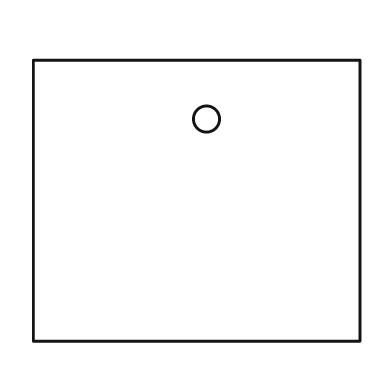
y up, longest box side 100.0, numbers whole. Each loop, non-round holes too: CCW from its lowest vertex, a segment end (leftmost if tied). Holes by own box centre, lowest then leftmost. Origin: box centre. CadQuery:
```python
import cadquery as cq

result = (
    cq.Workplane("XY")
    .moveTo(-50.0, -43.0)
    .lineTo(50.0, -43.0)
    .lineTo(50.0, 43.0)
    .lineTo(-50.0, 43.0)
    .close()
    .moveTo(3.0, 25.0)
    .circle(4.0)
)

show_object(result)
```